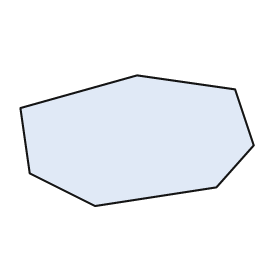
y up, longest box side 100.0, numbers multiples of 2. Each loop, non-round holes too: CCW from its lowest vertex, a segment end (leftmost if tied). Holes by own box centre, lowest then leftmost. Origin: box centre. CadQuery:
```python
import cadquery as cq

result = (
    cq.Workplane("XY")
    .moveTo(-18.0, -28.0)
    .lineTo(34.0, -20.0)
    .lineTo(50.0, -2.0)
    .lineTo(42.0, 22.0)
    .lineTo(0.0, 28.0)
    .lineTo(-50.0, 14.0)
    .lineTo(-46.0, -14.0)
    .close()
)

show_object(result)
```